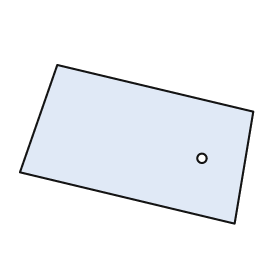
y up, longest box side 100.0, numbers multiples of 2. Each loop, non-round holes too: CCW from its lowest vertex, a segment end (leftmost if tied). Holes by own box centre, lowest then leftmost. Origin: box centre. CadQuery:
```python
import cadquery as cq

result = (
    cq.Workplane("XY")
    .moveTo(42.0, -34.0)
    .lineTo(50.0, 14.0)
    .lineTo(-34.0, 34.0)
    .lineTo(-50.0, -12.0)
    .close()
    .moveTo(28.0, -6.0)
    .circle(2.0)
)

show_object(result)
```